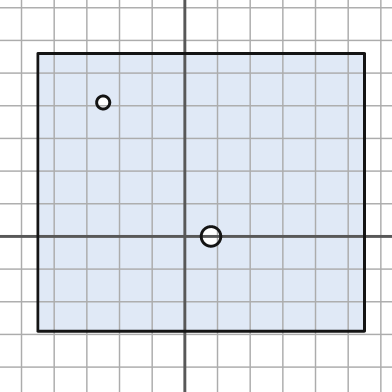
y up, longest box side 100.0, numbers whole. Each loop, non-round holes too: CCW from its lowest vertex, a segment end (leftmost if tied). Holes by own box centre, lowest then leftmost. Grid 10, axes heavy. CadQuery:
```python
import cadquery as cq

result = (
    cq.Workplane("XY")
    .moveTo(-45.0, -29.0)
    .lineTo(55.0, -29.0)
    .lineTo(55.0, 56.0)
    .lineTo(-45.0, 56.0)
    .close()
    .moveTo(8.0, 0.0)
    .circle(3.0)
    .moveTo(-25.0, 41.0)
    .circle(2.0)
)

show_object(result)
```